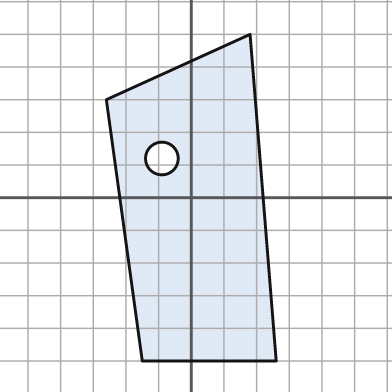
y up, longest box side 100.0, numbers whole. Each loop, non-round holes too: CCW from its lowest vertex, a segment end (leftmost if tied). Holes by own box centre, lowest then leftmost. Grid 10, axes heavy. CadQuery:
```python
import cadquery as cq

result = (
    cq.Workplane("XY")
    .moveTo(-15.0, -50.0)
    .lineTo(26.0, -50.0)
    .lineTo(18.0, 50.0)
    .lineTo(-26.0, 30.0)
    .close()
    .moveTo(-9.0, 12.0)
    .circle(5.0)
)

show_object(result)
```